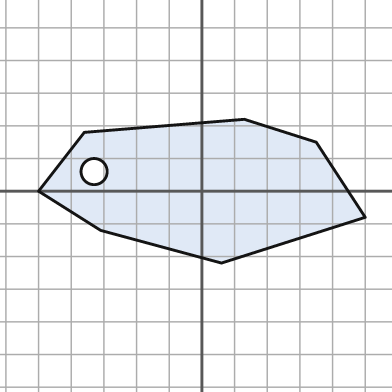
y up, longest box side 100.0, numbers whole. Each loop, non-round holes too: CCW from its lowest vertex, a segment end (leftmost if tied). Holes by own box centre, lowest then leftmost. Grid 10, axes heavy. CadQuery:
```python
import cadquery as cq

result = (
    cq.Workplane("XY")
    .moveTo(6.0, -22.0)
    .lineTo(50.0, -8.0)
    .lineTo(35.0, 15.0)
    .lineTo(13.0, 22.0)
    .lineTo(-36.0, 18.0)
    .lineTo(-50.0, 0.0)
    .lineTo(-31.0, -12.0)
    .close()
    .moveTo(-33.0, 6.0)
    .circle(4.0)
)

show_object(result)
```